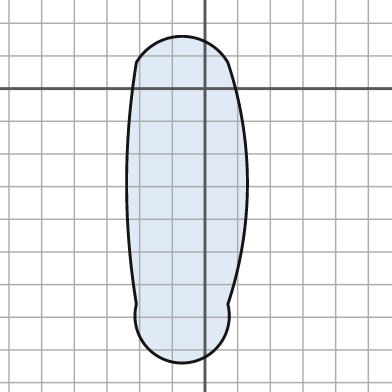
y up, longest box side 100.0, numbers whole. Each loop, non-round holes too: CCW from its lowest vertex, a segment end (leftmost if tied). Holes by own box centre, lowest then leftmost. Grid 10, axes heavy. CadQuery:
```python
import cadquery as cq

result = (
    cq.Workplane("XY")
    .moveTo(-21.0, -66.0)
    .threePointArc((-7.0, -84.0), (7.0, -66.0))
    .threePointArc((13.0, -29.0), (7.0, 8.0))
    .threePointArc((-7.0, 16.0), (-21.0, 8.0))
    .threePointArc((-24.0, -29.0), (-21.0, -66.0))
    .close()
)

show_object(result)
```